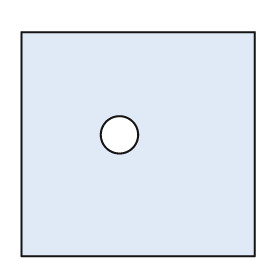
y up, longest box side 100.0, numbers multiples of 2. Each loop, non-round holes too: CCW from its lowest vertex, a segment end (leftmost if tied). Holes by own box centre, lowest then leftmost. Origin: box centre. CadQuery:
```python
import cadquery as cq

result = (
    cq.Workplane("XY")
    .moveTo(-50.0, -48.0)
    .lineTo(50.0, -48.0)
    .lineTo(50.0, 48.0)
    .lineTo(-50.0, 48.0)
    .close()
    .moveTo(-8.0, 4.0)
    .circle(8.0)
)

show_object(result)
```